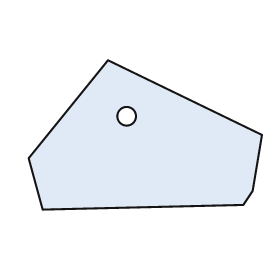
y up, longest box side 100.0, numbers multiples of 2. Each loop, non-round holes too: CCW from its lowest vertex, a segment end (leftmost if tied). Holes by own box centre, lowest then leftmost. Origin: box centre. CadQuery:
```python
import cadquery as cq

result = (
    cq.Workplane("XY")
    .moveTo(-44.0, -32.0)
    .lineTo(42.0, -30.0)
    .lineTo(46.0, -24.0)
    .lineTo(50.0, 0.0)
    .lineTo(-16.0, 32.0)
    .lineTo(-50.0, -10.0)
    .close()
    .moveTo(-8.0, 8.0)
    .circle(4.0)
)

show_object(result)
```